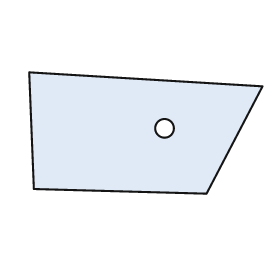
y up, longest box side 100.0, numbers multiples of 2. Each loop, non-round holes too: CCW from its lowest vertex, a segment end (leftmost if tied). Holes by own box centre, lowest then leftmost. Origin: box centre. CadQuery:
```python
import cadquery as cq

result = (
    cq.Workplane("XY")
    .moveTo(26.0, -26.0)
    .lineTo(50.0, 20.0)
    .lineTo(-50.0, 26.0)
    .lineTo(-48.0, -24.0)
    .close()
    .moveTo(8.0, 2.0)
    .circle(4.0)
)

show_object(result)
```